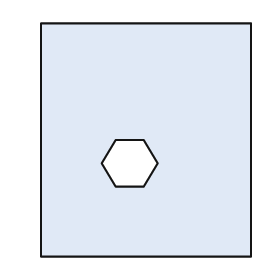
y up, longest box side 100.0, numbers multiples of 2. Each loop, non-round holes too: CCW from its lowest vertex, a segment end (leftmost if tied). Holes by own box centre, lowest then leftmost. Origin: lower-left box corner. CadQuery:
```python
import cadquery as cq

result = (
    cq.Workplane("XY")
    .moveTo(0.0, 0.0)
    .lineTo(90.0, 0.0)
    .lineTo(90.0, 100.0)
    .lineTo(0.0, 100.0)
    .close()
    .moveTo(32.0, 30.0)
    .lineTo(44.0, 30.0)
    .lineTo(50.0, 40.0)
    .lineTo(44.0, 50.0)
    .lineTo(32.0, 50.0)
    .lineTo(26.0, 40.0)
    .close()
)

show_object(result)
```